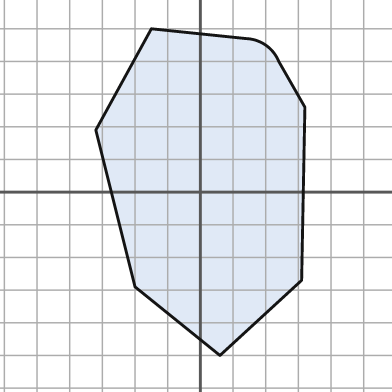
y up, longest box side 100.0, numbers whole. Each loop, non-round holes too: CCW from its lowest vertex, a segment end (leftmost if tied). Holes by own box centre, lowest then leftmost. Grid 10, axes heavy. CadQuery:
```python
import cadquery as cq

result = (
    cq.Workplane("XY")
    .moveTo(6.0, -50.0)
    .lineTo(31.0, -27.0)
    .lineTo(32.0, 26.0)
    .lineTo(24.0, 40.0)
    .threePointArc((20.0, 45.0), (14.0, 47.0))
    .lineTo(-15.0, 50.0)
    .lineTo(-32.0, 19.0)
    .lineTo(-20.0, -29.0)
    .close()
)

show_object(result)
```